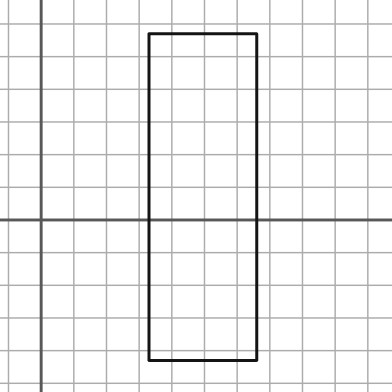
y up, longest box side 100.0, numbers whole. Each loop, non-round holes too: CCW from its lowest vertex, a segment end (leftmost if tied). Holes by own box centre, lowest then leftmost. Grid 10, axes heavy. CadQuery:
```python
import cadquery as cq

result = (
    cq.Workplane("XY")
    .moveTo(33.0, -43.0)
    .lineTo(66.0, -43.0)
    .lineTo(66.0, 57.0)
    .lineTo(33.0, 57.0)
    .close()
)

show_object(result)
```